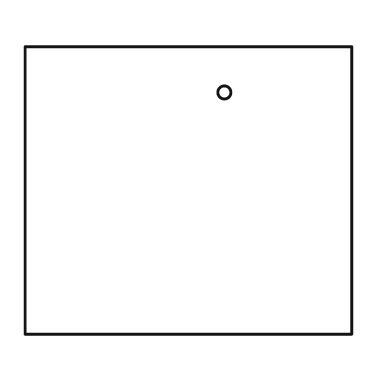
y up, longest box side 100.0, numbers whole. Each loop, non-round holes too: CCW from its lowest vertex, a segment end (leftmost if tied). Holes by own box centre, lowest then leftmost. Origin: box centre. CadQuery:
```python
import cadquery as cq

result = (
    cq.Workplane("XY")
    .moveTo(-50.0, -44.0)
    .lineTo(50.0, -44.0)
    .lineTo(50.0, 44.0)
    .lineTo(-50.0, 44.0)
    .close()
    .moveTo(11.0, 30.0)
    .circle(2.0)
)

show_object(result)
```